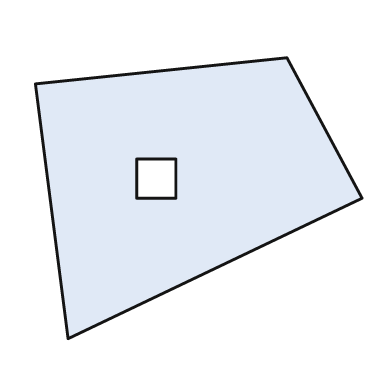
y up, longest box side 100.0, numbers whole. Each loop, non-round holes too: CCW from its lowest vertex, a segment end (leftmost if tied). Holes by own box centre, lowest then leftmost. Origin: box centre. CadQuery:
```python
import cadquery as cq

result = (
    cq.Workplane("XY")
    .moveTo(-40.0, -43.0)
    .lineTo(50.0, 0.0)
    .lineTo(27.0, 43.0)
    .lineTo(-50.0, 35.0)
    .close()
    .moveTo(-19.0, 0.0)
    .lineTo(-7.0, 0.0)
    .lineTo(-7.0, 12.0)
    .lineTo(-19.0, 12.0)
    .close()
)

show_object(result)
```